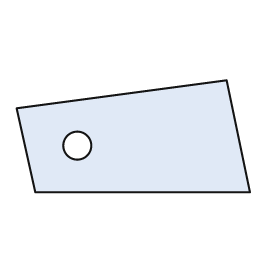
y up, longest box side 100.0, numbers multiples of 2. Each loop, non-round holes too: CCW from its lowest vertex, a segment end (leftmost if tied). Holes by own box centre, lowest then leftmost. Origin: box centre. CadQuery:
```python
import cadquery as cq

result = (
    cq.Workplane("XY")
    .moveTo(-42.0, -24.0)
    .lineTo(50.0, -24.0)
    .lineTo(40.0, 24.0)
    .lineTo(-50.0, 12.0)
    .close()
    .moveTo(-24.0, -4.0)
    .circle(6.0)
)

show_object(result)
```